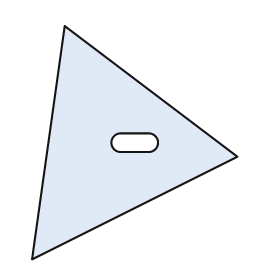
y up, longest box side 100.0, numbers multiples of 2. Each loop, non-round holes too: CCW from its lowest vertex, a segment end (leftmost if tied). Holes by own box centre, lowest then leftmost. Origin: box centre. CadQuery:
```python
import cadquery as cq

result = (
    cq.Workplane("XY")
    .moveTo(-44.0, -50.0)
    .lineTo(44.0, -6.0)
    .lineTo(-30.0, 50.0)
    .close()
    .moveTo(-6.0, -4.0)
    .lineTo(6.0, -4.0)
    .threePointArc((10.0, 0.0), (6.0, 4.0))
    .lineTo(-6.0, 4.0)
    .threePointArc((-10.0, 0.0), (-6.0, -4.0))
    .close()
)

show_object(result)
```